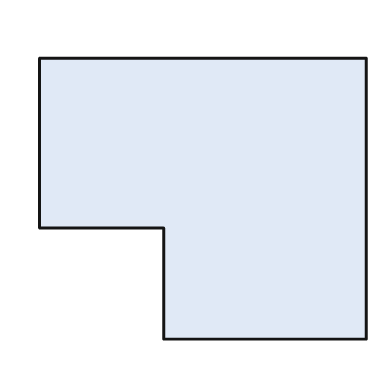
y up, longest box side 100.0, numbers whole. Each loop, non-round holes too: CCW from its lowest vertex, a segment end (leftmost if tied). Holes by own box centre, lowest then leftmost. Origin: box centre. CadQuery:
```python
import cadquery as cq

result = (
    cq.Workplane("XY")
    .moveTo(-12.0, -43.0)
    .lineTo(50.0, -43.0)
    .lineTo(50.0, 43.0)
    .lineTo(-50.0, 43.0)
    .lineTo(-50.0, -9.0)
    .lineTo(-12.0, -9.0)
    .close()
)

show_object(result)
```